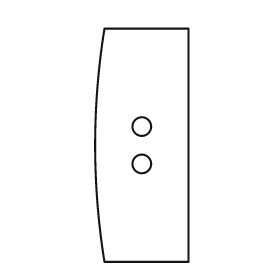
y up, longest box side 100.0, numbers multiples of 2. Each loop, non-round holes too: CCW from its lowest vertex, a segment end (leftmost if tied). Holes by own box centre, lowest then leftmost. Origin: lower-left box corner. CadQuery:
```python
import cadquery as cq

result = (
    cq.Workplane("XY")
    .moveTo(4.0, 0.0)
    .lineTo(40.0, 0.0)
    .lineTo(40.0, 100.0)
    .lineTo(4.0, 100.0)
    .threePointArc((0.0, 50.0), (4.0, 0.0))
    .close()
    .moveTo(20.0, 42.0)
    .circle(4.0)
    .moveTo(20.0, 58.0)
    .circle(4.0)
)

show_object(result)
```